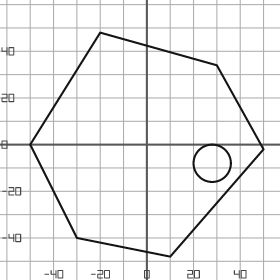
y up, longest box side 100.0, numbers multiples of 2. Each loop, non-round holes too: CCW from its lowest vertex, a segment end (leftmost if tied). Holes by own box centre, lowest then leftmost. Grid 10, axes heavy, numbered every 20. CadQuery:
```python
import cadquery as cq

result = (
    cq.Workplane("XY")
    .moveTo(10.0, -48.0)
    .lineTo(50.0, -2.0)
    .lineTo(30.0, 34.0)
    .lineTo(-20.0, 48.0)
    .lineTo(-50.0, 0.0)
    .lineTo(-30.0, -40.0)
    .close()
    .moveTo(28.0, -8.0)
    .circle(8.0)
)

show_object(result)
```